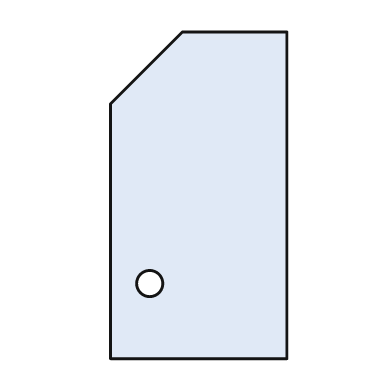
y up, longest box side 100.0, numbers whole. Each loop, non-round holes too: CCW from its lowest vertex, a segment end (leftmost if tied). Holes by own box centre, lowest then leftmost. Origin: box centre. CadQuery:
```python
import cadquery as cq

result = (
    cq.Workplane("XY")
    .moveTo(-27.0, -50.0)
    .lineTo(27.0, -50.0)
    .lineTo(27.0, 50.0)
    .lineTo(-5.0, 50.0)
    .lineTo(-27.0, 28.0)
    .close()
    .moveTo(-15.0, -27.0)
    .circle(4.0)
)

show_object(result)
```